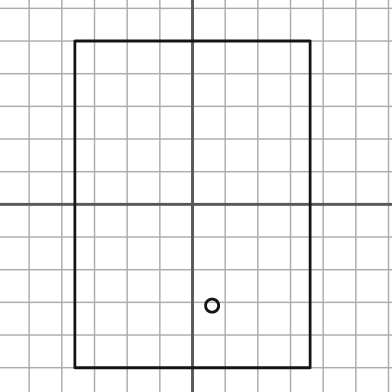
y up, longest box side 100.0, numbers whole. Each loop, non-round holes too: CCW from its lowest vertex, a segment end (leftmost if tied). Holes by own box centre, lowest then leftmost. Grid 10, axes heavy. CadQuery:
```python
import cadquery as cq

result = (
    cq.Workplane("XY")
    .moveTo(-36.0, -50.0)
    .lineTo(36.0, -50.0)
    .lineTo(36.0, 50.0)
    .lineTo(-36.0, 50.0)
    .close()
    .moveTo(6.0, -31.0)
    .circle(2.0)
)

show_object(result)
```